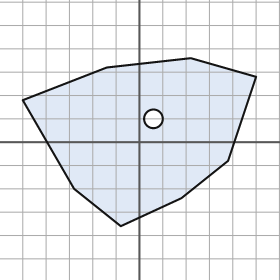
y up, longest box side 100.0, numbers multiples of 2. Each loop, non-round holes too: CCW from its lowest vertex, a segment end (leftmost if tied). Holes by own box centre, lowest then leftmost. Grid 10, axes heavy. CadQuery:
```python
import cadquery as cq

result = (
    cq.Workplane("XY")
    .moveTo(-8.0, -36.0)
    .lineTo(18.0, -24.0)
    .lineTo(38.0, -8.0)
    .lineTo(50.0, 28.0)
    .lineTo(22.0, 36.0)
    .lineTo(-14.0, 32.0)
    .lineTo(-50.0, 18.0)
    .lineTo(-28.0, -20.0)
    .close()
    .moveTo(6.0, 10.0)
    .circle(4.0)
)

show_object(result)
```